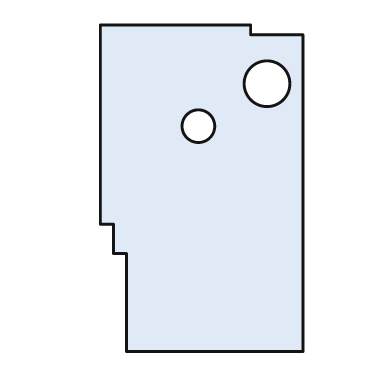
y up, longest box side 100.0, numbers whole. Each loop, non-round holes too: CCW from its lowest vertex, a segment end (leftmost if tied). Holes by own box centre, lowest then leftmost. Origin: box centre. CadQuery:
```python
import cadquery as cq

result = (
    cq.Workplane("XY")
    .moveTo(-23.0, -50.0)
    .lineTo(31.0, -50.0)
    .lineTo(31.0, 47.0)
    .lineTo(15.0, 47.0)
    .lineTo(15.0, 50.0)
    .lineTo(-31.0, 50.0)
    .lineTo(-31.0, -11.0)
    .lineTo(-27.0, -11.0)
    .lineTo(-27.0, -20.0)
    .lineTo(-23.0, -20.0)
    .close()
    .moveTo(-1.0, 19.0)
    .circle(5.0)
    .moveTo(20.0, 32.0)
    .circle(7.0)
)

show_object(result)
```